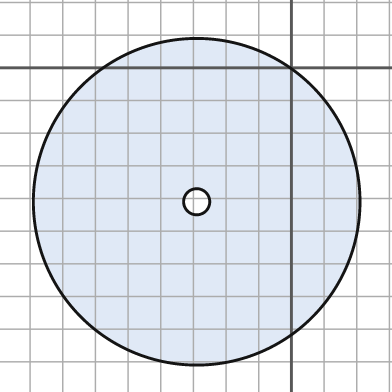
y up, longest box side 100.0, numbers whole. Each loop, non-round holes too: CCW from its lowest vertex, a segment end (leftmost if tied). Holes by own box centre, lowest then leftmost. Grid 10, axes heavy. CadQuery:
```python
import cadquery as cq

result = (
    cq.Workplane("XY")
    .moveTo(-29.0, -41.0)
    .circle(50.0)
    .moveTo(-29.0, -41.0)
    .circle(4.0)
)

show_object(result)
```